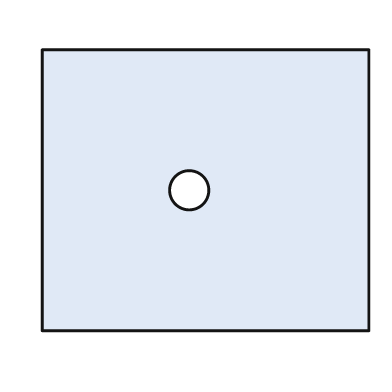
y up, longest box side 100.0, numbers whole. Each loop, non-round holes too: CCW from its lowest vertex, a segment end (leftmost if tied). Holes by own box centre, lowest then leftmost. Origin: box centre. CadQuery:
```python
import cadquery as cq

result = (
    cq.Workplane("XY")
    .moveTo(-50.0, -43.0)
    .lineTo(50.0, -43.0)
    .lineTo(50.0, 43.0)
    .lineTo(-50.0, 43.0)
    .close()
    .moveTo(-5.0, 0.0)
    .circle(6.0)
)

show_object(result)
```